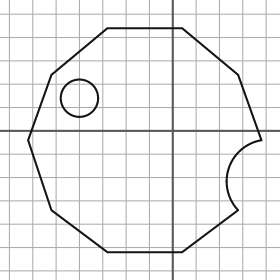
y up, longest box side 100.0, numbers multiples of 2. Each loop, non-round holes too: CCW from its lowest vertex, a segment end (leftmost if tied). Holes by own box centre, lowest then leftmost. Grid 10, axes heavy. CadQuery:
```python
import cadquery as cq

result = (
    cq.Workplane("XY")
    .moveTo(-28.0, -52.0)
    .lineTo(4.0, -52.0)
    .lineTo(28.0, -34.0)
    .threePointArc((24.0, -16.0), (38.0, -4.0))
    .lineTo(28.0, 24.0)
    .lineTo(4.0, 44.0)
    .lineTo(-28.0, 44.0)
    .lineTo(-52.0, 24.0)
    .lineTo(-62.0, -4.0)
    .lineTo(-52.0, -34.0)
    .close()
    .moveTo(-40.0, 14.0)
    .circle(8.0)
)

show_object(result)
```